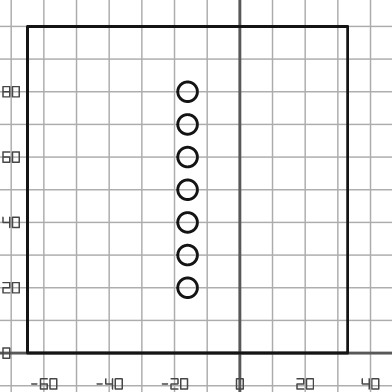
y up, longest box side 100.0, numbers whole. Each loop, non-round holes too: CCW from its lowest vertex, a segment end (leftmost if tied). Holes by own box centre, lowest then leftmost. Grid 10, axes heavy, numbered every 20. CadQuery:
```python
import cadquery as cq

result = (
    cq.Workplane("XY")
    .moveTo(-65.0, 0.0)
    .lineTo(33.0, 0.0)
    .lineTo(33.0, 100.0)
    .lineTo(-65.0, 100.0)
    .close()
    .moveTo(-16.0, 20.0)
    .circle(3.0)
    .moveTo(-16.0, 30.0)
    .circle(3.0)
    .moveTo(-16.0, 40.0)
    .circle(3.0)
    .moveTo(-16.0, 50.0)
    .circle(3.0)
    .moveTo(-16.0, 60.0)
    .circle(3.0)
    .moveTo(-16.0, 70.0)
    .circle(3.0)
    .moveTo(-16.0, 80.0)
    .circle(3.0)
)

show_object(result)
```